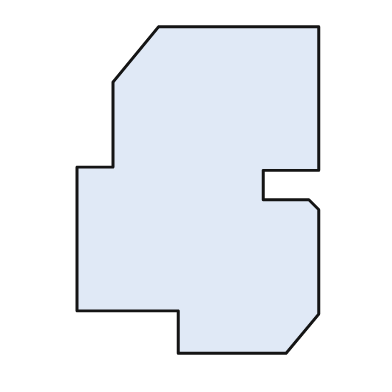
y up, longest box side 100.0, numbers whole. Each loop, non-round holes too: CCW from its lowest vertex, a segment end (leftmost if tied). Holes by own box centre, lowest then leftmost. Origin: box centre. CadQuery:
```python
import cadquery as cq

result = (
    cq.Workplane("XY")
    .moveTo(-6.0, -50.0)
    .lineTo(27.0, -50.0)
    .lineTo(37.0, -38.0)
    .lineTo(37.0, -6.0)
    .lineTo(34.0, -3.0)
    .lineTo(20.0, -3.0)
    .lineTo(20.0, 6.0)
    .lineTo(37.0, 6.0)
    .lineTo(37.0, 50.0)
    .lineTo(-12.0, 50.0)
    .lineTo(-26.0, 33.0)
    .lineTo(-26.0, 7.0)
    .lineTo(-37.0, 7.0)
    .lineTo(-37.0, -37.0)
    .lineTo(-6.0, -37.0)
    .close()
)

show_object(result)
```